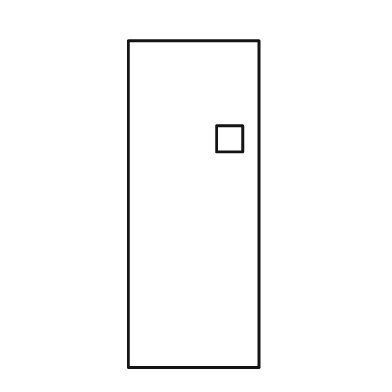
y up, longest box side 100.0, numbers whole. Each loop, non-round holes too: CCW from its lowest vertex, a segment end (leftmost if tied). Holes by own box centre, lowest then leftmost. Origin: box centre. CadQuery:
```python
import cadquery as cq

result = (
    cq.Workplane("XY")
    .moveTo(-20.0, -50.0)
    .lineTo(20.0, -50.0)
    .lineTo(20.0, 50.0)
    .lineTo(-20.0, 50.0)
    .close()
    .moveTo(7.0, 16.0)
    .lineTo(15.0, 16.0)
    .lineTo(15.0, 24.0)
    .lineTo(7.0, 24.0)
    .close()
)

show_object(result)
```